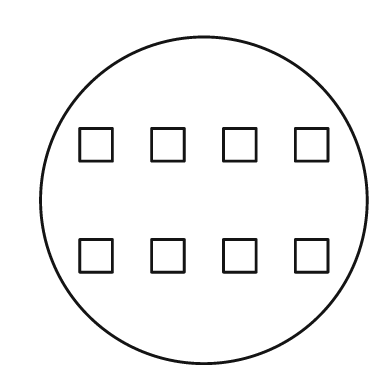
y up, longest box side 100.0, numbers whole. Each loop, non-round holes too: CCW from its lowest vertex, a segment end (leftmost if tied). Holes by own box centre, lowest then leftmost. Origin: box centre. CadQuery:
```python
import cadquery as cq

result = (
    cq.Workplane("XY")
    .moveTo(0.0, 0.0)
    .circle(50.0)
    .moveTo(-38.0, -22.0)
    .lineTo(-28.0, -22.0)
    .lineTo(-28.0, -12.0)
    .lineTo(-38.0, -12.0)
    .close()
    .moveTo(-16.0, -22.0)
    .lineTo(-6.0, -22.0)
    .lineTo(-6.0, -12.0)
    .lineTo(-16.0, -12.0)
    .close()
    .moveTo(6.0, -22.0)
    .lineTo(16.0, -22.0)
    .lineTo(16.0, -12.0)
    .lineTo(6.0, -12.0)
    .close()
    .moveTo(28.0, -22.0)
    .lineTo(38.0, -22.0)
    .lineTo(38.0, -12.0)
    .lineTo(28.0, -12.0)
    .close()
    .moveTo(-38.0, 12.0)
    .lineTo(-28.0, 12.0)
    .lineTo(-28.0, 22.0)
    .lineTo(-38.0, 22.0)
    .close()
    .moveTo(-16.0, 12.0)
    .lineTo(-6.0, 12.0)
    .lineTo(-6.0, 22.0)
    .lineTo(-16.0, 22.0)
    .close()
    .moveTo(6.0, 12.0)
    .lineTo(16.0, 12.0)
    .lineTo(16.0, 22.0)
    .lineTo(6.0, 22.0)
    .close()
    .moveTo(28.0, 12.0)
    .lineTo(38.0, 12.0)
    .lineTo(38.0, 22.0)
    .lineTo(28.0, 22.0)
    .close()
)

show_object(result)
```